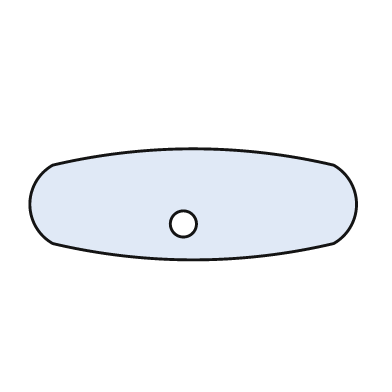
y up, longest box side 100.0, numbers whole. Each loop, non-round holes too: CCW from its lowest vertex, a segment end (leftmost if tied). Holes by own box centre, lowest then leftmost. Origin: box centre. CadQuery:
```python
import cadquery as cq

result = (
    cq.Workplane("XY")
    .moveTo(-43.0, -12.0)
    .threePointArc((0.0, -17.0), (43.0, -12.0))
    .threePointArc((50.0, 0.0), (43.0, 12.0))
    .threePointArc((0.0, 17.0), (-43.0, 12.0))
    .threePointArc((-50.0, 0.0), (-43.0, -12.0))
    .close()
    .moveTo(-3.0, -6.0)
    .circle(4.0)
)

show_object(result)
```